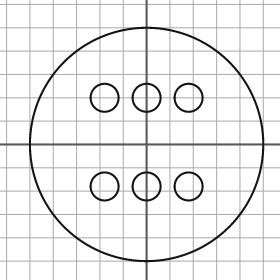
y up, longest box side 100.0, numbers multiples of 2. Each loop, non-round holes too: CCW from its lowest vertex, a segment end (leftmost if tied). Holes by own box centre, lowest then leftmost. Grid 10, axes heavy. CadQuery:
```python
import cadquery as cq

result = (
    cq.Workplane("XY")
    .moveTo(0.0, 0.0)
    .circle(50.0)
    .moveTo(-18.0, -18.0)
    .circle(6.0)
    .moveTo(0.0, -18.0)
    .circle(6.0)
    .moveTo(18.0, -18.0)
    .circle(6.0)
    .moveTo(-18.0, 20.0)
    .circle(6.0)
    .moveTo(0.0, 20.0)
    .circle(6.0)
    .moveTo(18.0, 20.0)
    .circle(6.0)
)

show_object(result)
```